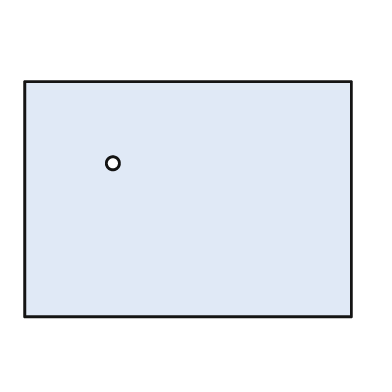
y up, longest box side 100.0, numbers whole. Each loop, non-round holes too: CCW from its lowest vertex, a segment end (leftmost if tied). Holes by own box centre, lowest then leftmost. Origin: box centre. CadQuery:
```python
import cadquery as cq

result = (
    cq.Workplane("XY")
    .moveTo(-50.0, -36.0)
    .lineTo(50.0, -36.0)
    .lineTo(50.0, 36.0)
    .lineTo(-50.0, 36.0)
    .close()
    .moveTo(-23.0, 11.0)
    .circle(2.0)
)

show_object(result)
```